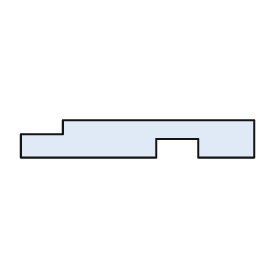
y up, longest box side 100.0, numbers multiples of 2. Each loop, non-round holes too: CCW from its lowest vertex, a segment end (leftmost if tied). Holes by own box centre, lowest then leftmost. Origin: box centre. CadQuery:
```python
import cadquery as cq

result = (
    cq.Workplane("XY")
    .moveTo(-50.0, -8.0)
    .lineTo(8.0, -8.0)
    .lineTo(8.0, 0.0)
    .lineTo(26.0, 0.0)
    .lineTo(26.0, -8.0)
    .lineTo(50.0, -8.0)
    .lineTo(50.0, 8.0)
    .lineTo(-32.0, 8.0)
    .lineTo(-32.0, 2.0)
    .lineTo(-50.0, 2.0)
    .close()
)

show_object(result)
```